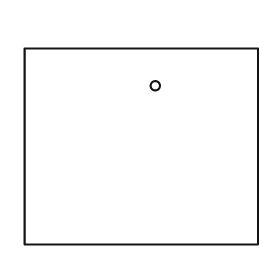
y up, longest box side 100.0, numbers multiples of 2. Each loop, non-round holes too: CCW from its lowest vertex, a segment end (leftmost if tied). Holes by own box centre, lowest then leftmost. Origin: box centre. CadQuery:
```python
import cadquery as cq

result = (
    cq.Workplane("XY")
    .moveTo(-50.0, -42.0)
    .lineTo(50.0, -42.0)
    .lineTo(50.0, 42.0)
    .lineTo(-50.0, 42.0)
    .close()
    .moveTo(6.0, 26.0)
    .circle(2.0)
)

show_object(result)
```